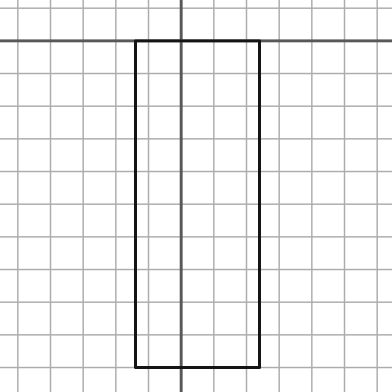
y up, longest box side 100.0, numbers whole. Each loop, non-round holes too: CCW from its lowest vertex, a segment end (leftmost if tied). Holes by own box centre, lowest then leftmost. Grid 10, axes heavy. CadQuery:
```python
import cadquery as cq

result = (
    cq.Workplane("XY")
    .moveTo(-14.0, -100.0)
    .lineTo(24.0, -100.0)
    .lineTo(24.0, 0.0)
    .lineTo(-14.0, 0.0)
    .close()
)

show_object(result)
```